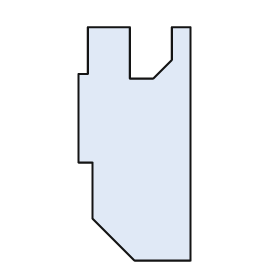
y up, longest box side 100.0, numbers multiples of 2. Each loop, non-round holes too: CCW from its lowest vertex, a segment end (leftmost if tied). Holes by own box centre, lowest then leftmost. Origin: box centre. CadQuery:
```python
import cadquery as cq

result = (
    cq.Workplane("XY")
    .moveTo(0.0, -50.0)
    .lineTo(24.0, -50.0)
    .lineTo(24.0, 50.0)
    .lineTo(16.0, 50.0)
    .lineTo(16.0, 36.0)
    .lineTo(8.0, 28.0)
    .lineTo(-2.0, 28.0)
    .lineTo(-2.0, 50.0)
    .lineTo(-20.0, 50.0)
    .lineTo(-20.0, 30.0)
    .lineTo(-24.0, 30.0)
    .lineTo(-24.0, -8.0)
    .lineTo(-18.0, -8.0)
    .lineTo(-18.0, -32.0)
    .close()
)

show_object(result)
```